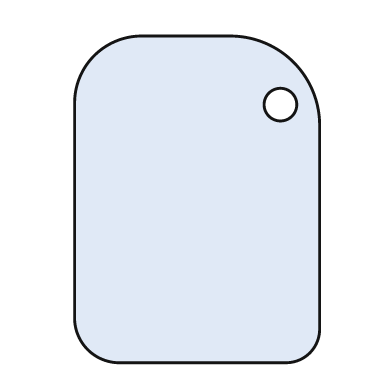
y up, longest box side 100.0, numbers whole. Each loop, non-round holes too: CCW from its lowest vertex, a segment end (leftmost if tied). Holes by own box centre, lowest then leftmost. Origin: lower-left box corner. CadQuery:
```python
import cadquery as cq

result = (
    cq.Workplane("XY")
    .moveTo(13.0, 0.0)
    .lineTo(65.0, 0.0)
    .threePointArc((72.0, 3.0), (75.0, 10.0))
    .lineTo(75.0, 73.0)
    .threePointArc((67.0, 92.0), (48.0, 100.0))
    .lineTo(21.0, 100.0)
    .threePointArc((6.0, 94.0), (0.0, 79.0))
    .lineTo(0.0, 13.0)
    .threePointArc((4.0, 4.0), (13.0, 0.0))
    .close()
    .moveTo(63.0, 79.0)
    .circle(5.0)
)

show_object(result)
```